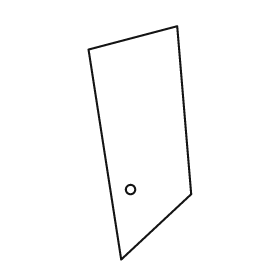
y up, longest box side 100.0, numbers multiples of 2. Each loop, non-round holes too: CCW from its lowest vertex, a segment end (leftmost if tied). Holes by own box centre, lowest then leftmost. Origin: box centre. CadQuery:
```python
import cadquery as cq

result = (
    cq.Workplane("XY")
    .moveTo(-8.0, -50.0)
    .lineTo(22.0, -22.0)
    .lineTo(16.0, 50.0)
    .lineTo(-22.0, 40.0)
    .close()
    .moveTo(-4.0, -20.0)
    .circle(2.0)
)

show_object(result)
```